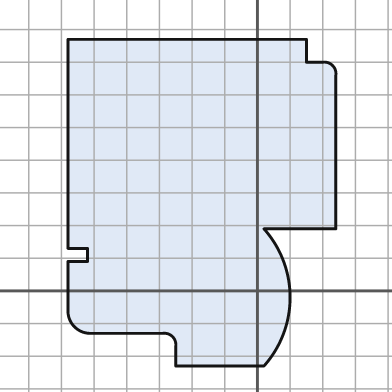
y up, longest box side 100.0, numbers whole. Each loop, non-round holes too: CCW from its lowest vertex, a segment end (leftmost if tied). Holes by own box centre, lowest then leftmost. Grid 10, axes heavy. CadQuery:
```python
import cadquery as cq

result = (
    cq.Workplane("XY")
    .moveTo(-25.0, -23.0)
    .lineTo(2.0, -23.0)
    .threePointArc((10.0, -2.0), (2.0, 19.0))
    .lineTo(24.0, 19.0)
    .lineTo(24.0, 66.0)
    .threePointArc((23.0, 69.0), (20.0, 70.0))
    .lineTo(15.0, 70.0)
    .lineTo(15.0, 77.0)
    .lineTo(-58.0, 77.0)
    .lineTo(-58.0, 13.0)
    .lineTo(-52.0, 13.0)
    .lineTo(-52.0, 9.0)
    .lineTo(-58.0, 9.0)
    .lineTo(-58.0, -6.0)
    .threePointArc((-56.0, -11.0), (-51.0, -13.0))
    .lineTo(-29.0, -13.0)
    .threePointArc((-26.0, -14.0), (-25.0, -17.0))
    .close()
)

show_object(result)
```